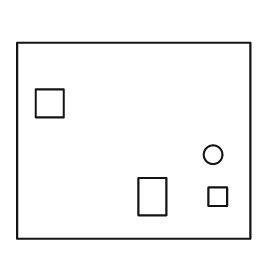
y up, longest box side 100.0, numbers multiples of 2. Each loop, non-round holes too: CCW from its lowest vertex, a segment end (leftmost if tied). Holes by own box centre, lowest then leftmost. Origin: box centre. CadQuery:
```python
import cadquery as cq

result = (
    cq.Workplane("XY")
    .moveTo(-50.0, -42.0)
    .lineTo(50.0, -42.0)
    .lineTo(50.0, 42.0)
    .lineTo(-50.0, 42.0)
    .close()
    .moveTo(2.0, -32.0)
    .lineTo(14.0, -32.0)
    .lineTo(14.0, -16.0)
    .lineTo(2.0, -16.0)
    .close()
    .moveTo(32.0, -28.0)
    .lineTo(40.0, -28.0)
    .lineTo(40.0, -20.0)
    .lineTo(32.0, -20.0)
    .close()
    .moveTo(34.0, -6.0)
    .circle(4.0)
    .moveTo(-42.0, 10.0)
    .lineTo(-30.0, 10.0)
    .lineTo(-30.0, 22.0)
    .lineTo(-42.0, 22.0)
    .close()
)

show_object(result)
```